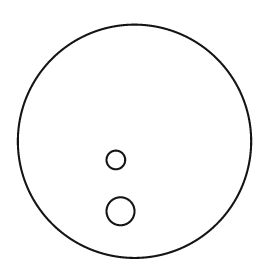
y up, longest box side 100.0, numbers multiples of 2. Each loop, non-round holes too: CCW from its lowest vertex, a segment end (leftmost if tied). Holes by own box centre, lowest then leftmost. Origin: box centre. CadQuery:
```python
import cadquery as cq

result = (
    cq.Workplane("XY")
    .moveTo(0.0, 0.0)
    .circle(50.0)
    .moveTo(-6.0, -30.0)
    .circle(6.0)
    .moveTo(-8.0, -8.0)
    .circle(4.0)
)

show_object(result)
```